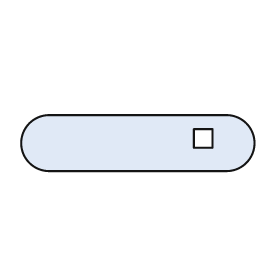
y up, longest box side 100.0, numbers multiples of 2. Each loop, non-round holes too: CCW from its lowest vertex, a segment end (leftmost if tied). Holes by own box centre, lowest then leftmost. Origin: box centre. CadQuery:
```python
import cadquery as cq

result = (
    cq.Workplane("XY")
    .moveTo(-38.0, -12.0)
    .lineTo(38.0, -12.0)
    .threePointArc((50.0, 0.0), (38.0, 12.0))
    .lineTo(-38.0, 12.0)
    .threePointArc((-50.0, 0.0), (-38.0, -12.0))
    .close()
    .moveTo(24.0, -2.0)
    .lineTo(32.0, -2.0)
    .lineTo(32.0, 6.0)
    .lineTo(24.0, 6.0)
    .close()
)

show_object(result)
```